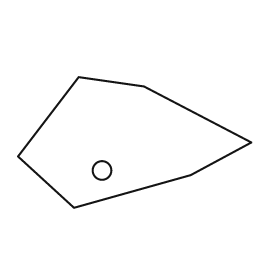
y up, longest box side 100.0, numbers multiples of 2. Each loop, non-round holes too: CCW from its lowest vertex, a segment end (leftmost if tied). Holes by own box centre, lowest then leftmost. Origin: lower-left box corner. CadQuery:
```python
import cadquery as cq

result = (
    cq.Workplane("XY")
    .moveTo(24.0, 0.0)
    .lineTo(74.0, 14.0)
    .lineTo(100.0, 28.0)
    .lineTo(54.0, 52.0)
    .lineTo(26.0, 56.0)
    .lineTo(0.0, 22.0)
    .close()
    .moveTo(36.0, 16.0)
    .circle(4.0)
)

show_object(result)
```